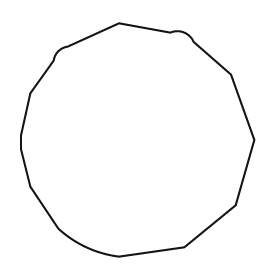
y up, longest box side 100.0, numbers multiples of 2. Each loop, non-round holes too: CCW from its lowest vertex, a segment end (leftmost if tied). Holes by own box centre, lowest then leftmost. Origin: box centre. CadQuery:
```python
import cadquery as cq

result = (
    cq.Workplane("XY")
    .moveTo(-8.0, -50.0)
    .lineTo(20.0, -46.0)
    .lineTo(42.0, -28.0)
    .lineTo(50.0, 0.0)
    .lineTo(40.0, 28.0)
    .lineTo(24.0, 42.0)
    .threePointArc((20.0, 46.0), (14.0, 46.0))
    .lineTo(-8.0, 50.0)
    .lineTo(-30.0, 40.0)
    .threePointArc((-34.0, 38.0), (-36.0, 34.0))
    .lineTo(-46.0, 20.0)
    .lineTo(-50.0, 2.0)
    .lineTo(-50.0, -4.0)
    .lineTo(-46.0, -20.0)
    .lineTo(-34.0, -38.0)
    .threePointArc((-22.0, -46.0), (-8.0, -50.0))
    .close()
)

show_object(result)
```